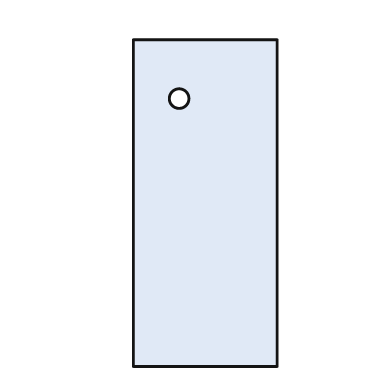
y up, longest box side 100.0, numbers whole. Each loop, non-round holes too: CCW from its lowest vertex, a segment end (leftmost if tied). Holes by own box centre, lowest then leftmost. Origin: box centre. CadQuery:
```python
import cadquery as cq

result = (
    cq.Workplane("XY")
    .moveTo(-22.0, -50.0)
    .lineTo(22.0, -50.0)
    .lineTo(22.0, 50.0)
    .lineTo(-22.0, 50.0)
    .close()
    .moveTo(-8.0, 32.0)
    .circle(3.0)
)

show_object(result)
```